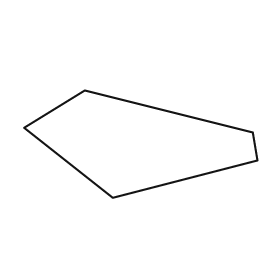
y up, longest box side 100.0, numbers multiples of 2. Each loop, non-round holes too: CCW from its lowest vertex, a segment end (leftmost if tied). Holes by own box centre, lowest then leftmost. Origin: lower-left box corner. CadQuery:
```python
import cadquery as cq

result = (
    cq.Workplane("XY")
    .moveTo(38.0, 0.0)
    .lineTo(100.0, 16.0)
    .lineTo(98.0, 28.0)
    .lineTo(26.0, 46.0)
    .lineTo(0.0, 30.0)
    .close()
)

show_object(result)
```